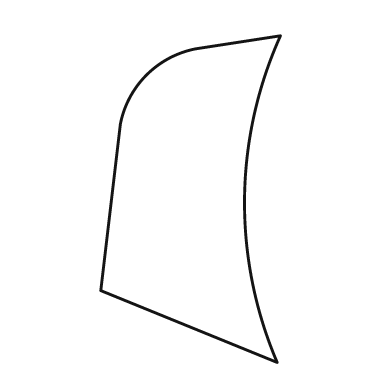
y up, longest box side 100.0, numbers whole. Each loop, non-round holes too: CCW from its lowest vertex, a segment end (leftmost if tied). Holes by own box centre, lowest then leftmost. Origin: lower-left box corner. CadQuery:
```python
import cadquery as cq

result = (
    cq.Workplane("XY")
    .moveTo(54.0, 0.0)
    .threePointArc((44.0, 50.0), (55.0, 100.0))
    .lineTo(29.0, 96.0)
    .threePointArc((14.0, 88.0), (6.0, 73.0))
    .lineTo(0.0, 22.0)
    .close()
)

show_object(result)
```